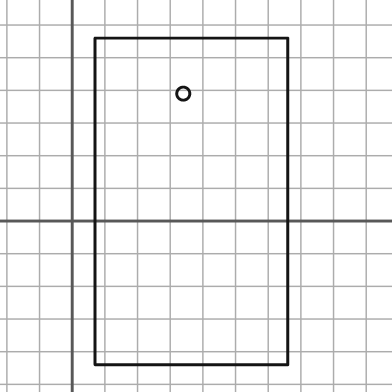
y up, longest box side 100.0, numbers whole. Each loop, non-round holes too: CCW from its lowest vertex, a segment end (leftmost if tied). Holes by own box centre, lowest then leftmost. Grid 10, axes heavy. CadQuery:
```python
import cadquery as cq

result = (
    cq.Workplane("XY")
    .moveTo(7.0, -44.0)
    .lineTo(66.0, -44.0)
    .lineTo(66.0, 56.0)
    .lineTo(7.0, 56.0)
    .close()
    .moveTo(34.0, 39.0)
    .circle(2.0)
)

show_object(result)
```